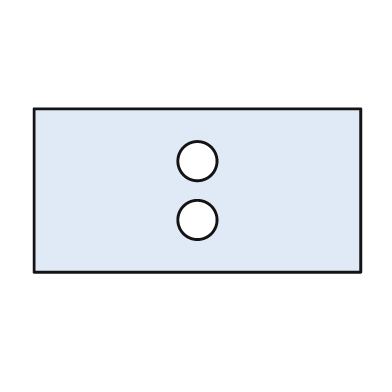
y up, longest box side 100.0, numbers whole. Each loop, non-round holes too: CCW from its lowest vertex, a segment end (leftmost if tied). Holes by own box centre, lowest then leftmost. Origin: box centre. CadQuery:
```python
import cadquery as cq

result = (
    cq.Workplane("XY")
    .moveTo(-50.0, -25.0)
    .lineTo(50.0, -25.0)
    .lineTo(50.0, 25.0)
    .lineTo(-50.0, 25.0)
    .close()
    .moveTo(0.0, -9.0)
    .circle(6.0)
    .moveTo(0.0, 9.0)
    .circle(6.0)
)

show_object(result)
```